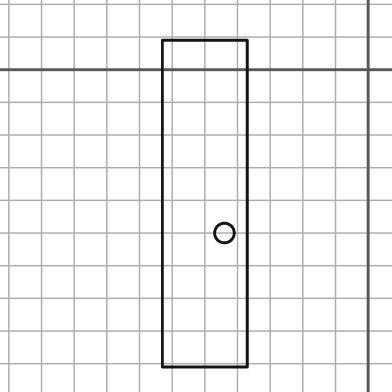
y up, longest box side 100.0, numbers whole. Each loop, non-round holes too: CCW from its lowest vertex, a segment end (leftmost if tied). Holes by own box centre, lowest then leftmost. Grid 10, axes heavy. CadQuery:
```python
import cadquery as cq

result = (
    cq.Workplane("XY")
    .moveTo(-63.0, -91.0)
    .lineTo(-37.0, -91.0)
    .lineTo(-37.0, 9.0)
    .lineTo(-63.0, 9.0)
    .close()
    .moveTo(-44.0, -50.0)
    .circle(3.0)
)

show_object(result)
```